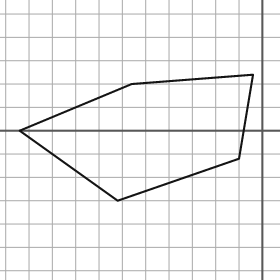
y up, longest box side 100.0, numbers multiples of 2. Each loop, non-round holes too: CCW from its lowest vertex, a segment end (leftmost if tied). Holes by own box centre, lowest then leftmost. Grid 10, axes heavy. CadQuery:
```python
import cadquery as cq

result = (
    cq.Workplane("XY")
    .moveTo(-62.0, -30.0)
    .lineTo(-10.0, -12.0)
    .lineTo(-4.0, 24.0)
    .lineTo(-56.0, 20.0)
    .lineTo(-104.0, 0.0)
    .close()
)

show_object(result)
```